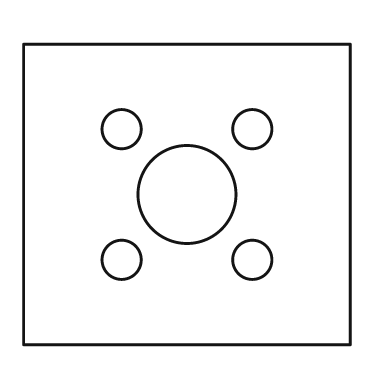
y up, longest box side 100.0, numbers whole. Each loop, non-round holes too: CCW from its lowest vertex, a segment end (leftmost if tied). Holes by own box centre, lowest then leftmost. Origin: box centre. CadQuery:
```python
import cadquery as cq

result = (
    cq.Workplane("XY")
    .moveTo(-50.0, -46.0)
    .lineTo(50.0, -46.0)
    .lineTo(50.0, 46.0)
    .lineTo(-50.0, 46.0)
    .close()
    .moveTo(-20.0, -20.0)
    .circle(6.0)
    .moveTo(20.0, -20.0)
    .circle(6.0)
    .moveTo(0.0, 0.0)
    .circle(15.0)
    .moveTo(-20.0, 20.0)
    .circle(6.0)
    .moveTo(20.0, 20.0)
    .circle(6.0)
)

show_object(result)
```